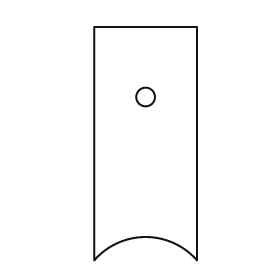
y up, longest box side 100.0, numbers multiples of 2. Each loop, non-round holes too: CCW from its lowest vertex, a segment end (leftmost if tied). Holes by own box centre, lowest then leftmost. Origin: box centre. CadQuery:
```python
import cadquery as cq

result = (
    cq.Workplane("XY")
    .moveTo(-22.0, -50.0)
    .threePointArc((0.0, -40.0), (22.0, -50.0))
    .lineTo(22.0, 50.0)
    .lineTo(-22.0, 50.0)
    .close()
    .moveTo(0.0, 20.0)
    .circle(4.0)
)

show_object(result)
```